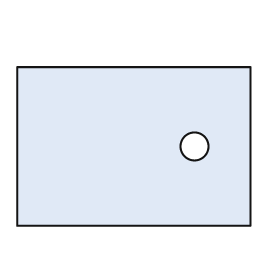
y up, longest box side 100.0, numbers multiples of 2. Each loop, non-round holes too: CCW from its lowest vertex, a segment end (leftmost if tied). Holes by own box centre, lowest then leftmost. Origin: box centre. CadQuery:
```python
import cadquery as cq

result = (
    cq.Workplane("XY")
    .moveTo(-50.0, -34.0)
    .lineTo(50.0, -34.0)
    .lineTo(50.0, 34.0)
    .lineTo(-50.0, 34.0)
    .close()
    .moveTo(26.0, 0.0)
    .circle(6.0)
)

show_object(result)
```